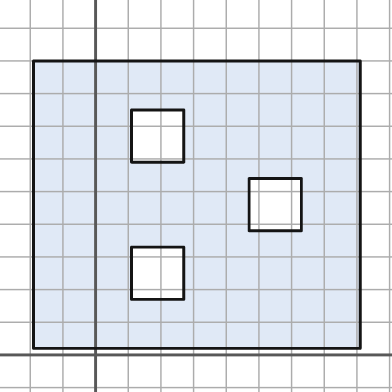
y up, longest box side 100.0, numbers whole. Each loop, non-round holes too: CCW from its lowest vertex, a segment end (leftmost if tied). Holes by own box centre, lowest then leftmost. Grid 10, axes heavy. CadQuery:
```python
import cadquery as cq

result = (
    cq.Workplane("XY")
    .moveTo(-19.0, 2.0)
    .lineTo(81.0, 2.0)
    .lineTo(81.0, 90.0)
    .lineTo(-19.0, 90.0)
    .close()
    .moveTo(11.0, 17.0)
    .lineTo(27.0, 17.0)
    .lineTo(27.0, 33.0)
    .lineTo(11.0, 33.0)
    .close()
    .moveTo(47.0, 38.0)
    .lineTo(63.0, 38.0)
    .lineTo(63.0, 54.0)
    .lineTo(47.0, 54.0)
    .close()
    .moveTo(11.0, 59.0)
    .lineTo(27.0, 59.0)
    .lineTo(27.0, 75.0)
    .lineTo(11.0, 75.0)
    .close()
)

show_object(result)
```